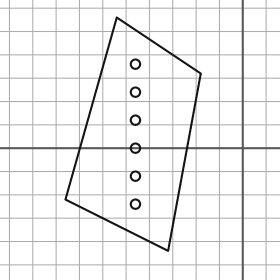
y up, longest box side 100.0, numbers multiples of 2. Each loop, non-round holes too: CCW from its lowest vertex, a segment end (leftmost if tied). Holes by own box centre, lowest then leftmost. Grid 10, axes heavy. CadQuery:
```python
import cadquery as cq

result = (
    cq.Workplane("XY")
    .moveTo(-32.0, -44.0)
    .lineTo(-18.0, 32.0)
    .lineTo(-54.0, 56.0)
    .lineTo(-76.0, -22.0)
    .close()
    .moveTo(-46.0, -24.0)
    .circle(2.0)
    .moveTo(-46.0, -12.0)
    .circle(2.0)
    .moveTo(-46.0, 0.0)
    .circle(2.0)
    .moveTo(-46.0, 12.0)
    .circle(2.0)
    .moveTo(-46.0, 24.0)
    .circle(2.0)
    .moveTo(-46.0, 36.0)
    .circle(2.0)
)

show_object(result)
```